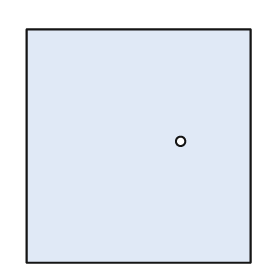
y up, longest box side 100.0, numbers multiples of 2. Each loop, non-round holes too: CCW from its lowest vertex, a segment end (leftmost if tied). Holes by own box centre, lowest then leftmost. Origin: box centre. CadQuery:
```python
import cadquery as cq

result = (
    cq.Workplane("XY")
    .moveTo(-48.0, -50.0)
    .lineTo(48.0, -50.0)
    .lineTo(48.0, 50.0)
    .lineTo(-48.0, 50.0)
    .close()
    .moveTo(18.0, 2.0)
    .circle(2.0)
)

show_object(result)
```